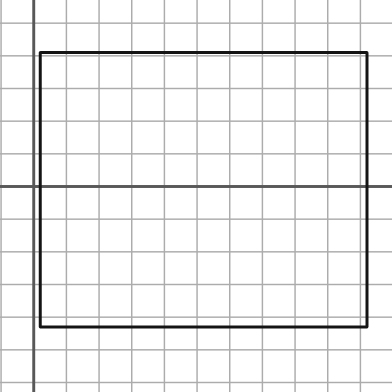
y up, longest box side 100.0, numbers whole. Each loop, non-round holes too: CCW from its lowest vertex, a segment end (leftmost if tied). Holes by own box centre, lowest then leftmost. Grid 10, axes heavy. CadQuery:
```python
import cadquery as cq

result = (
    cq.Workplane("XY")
    .moveTo(2.0, -43.0)
    .lineTo(102.0, -43.0)
    .lineTo(102.0, 41.0)
    .lineTo(2.0, 41.0)
    .close()
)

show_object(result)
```